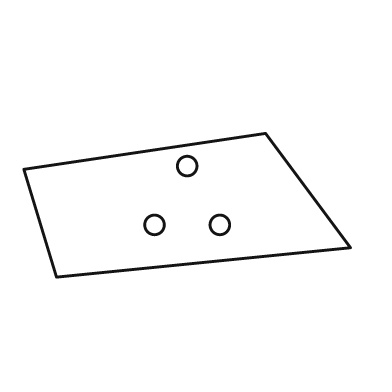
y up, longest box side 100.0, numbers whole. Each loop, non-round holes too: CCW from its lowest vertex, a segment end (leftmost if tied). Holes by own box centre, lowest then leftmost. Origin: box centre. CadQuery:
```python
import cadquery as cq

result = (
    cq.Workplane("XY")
    .moveTo(-40.0, -22.0)
    .lineTo(50.0, -13.0)
    .lineTo(24.0, 22.0)
    .lineTo(-50.0, 11.0)
    .close()
    .moveTo(-10.0, -6.0)
    .circle(3.0)
    .moveTo(10.0, -6.0)
    .circle(3.0)
    .moveTo(0.0, 12.0)
    .circle(3.0)
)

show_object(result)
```